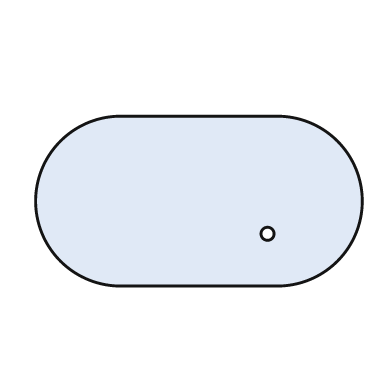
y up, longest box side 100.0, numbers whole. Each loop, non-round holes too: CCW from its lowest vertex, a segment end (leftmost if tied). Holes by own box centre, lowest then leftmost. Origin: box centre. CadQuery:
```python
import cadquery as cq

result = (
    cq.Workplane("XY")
    .moveTo(-24.0, -26.0)
    .lineTo(24.0, -26.0)
    .threePointArc((50.0, 0.0), (24.0, 26.0))
    .lineTo(-24.0, 26.0)
    .threePointArc((-50.0, 0.0), (-24.0, -26.0))
    .close()
    .moveTo(21.0, -10.0)
    .circle(2.0)
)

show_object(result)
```